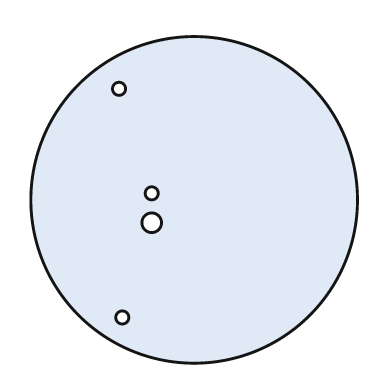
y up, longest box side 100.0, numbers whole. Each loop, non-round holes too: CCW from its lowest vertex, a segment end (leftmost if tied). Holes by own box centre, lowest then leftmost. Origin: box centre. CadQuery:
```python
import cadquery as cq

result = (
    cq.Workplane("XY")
    .moveTo(0.0, 0.0)
    .circle(50.0)
    .moveTo(-22.0, -36.0)
    .circle(2.0)
    .moveTo(-13.0, -7.0)
    .circle(3.0)
    .moveTo(-13.0, 2.0)
    .circle(2.0)
    .moveTo(-23.0, 34.0)
    .circle(2.0)
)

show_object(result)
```